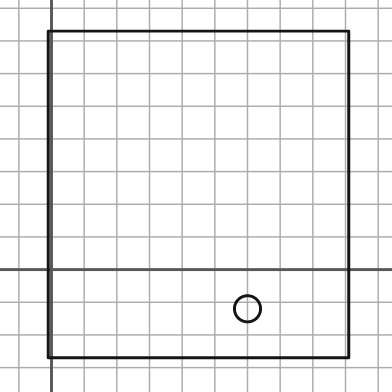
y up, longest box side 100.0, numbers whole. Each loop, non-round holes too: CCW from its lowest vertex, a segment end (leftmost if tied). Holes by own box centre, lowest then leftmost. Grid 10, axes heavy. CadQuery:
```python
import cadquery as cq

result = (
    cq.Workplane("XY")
    .moveTo(-1.0, -27.0)
    .lineTo(91.0, -27.0)
    .lineTo(91.0, 73.0)
    .lineTo(-1.0, 73.0)
    .close()
    .moveTo(60.0, -12.0)
    .circle(4.0)
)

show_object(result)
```